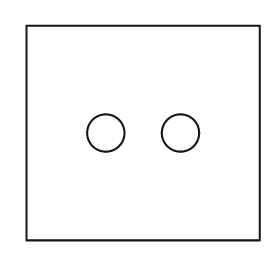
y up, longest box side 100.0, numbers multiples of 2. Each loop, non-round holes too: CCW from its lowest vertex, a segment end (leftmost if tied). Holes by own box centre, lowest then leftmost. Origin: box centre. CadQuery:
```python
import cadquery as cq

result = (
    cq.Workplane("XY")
    .moveTo(-50.0, -46.0)
    .lineTo(50.0, -46.0)
    .lineTo(50.0, 46.0)
    .lineTo(-50.0, 46.0)
    .close()
    .moveTo(-16.0, 0.0)
    .circle(8.0)
    .moveTo(16.0, 0.0)
    .circle(8.0)
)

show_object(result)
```